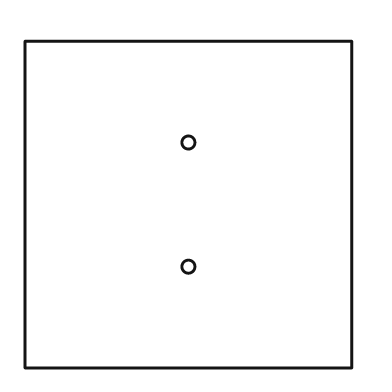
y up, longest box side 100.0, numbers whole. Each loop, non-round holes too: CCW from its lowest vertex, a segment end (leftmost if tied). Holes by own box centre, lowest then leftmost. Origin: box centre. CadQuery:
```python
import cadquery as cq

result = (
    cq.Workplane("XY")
    .moveTo(-50.0, -50.0)
    .lineTo(50.0, -50.0)
    .lineTo(50.0, 50.0)
    .lineTo(-50.0, 50.0)
    .close()
    .moveTo(0.0, -19.0)
    .circle(2.0)
    .moveTo(0.0, 19.0)
    .circle(2.0)
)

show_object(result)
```